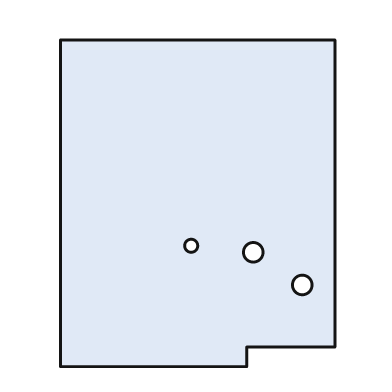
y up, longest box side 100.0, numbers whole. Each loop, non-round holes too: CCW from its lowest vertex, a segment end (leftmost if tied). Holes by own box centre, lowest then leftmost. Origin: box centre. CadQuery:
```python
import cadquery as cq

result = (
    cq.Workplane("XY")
    .moveTo(-42.0, -50.0)
    .lineTo(15.0, -50.0)
    .lineTo(15.0, -44.0)
    .lineTo(42.0, -44.0)
    .lineTo(42.0, 50.0)
    .lineTo(-42.0, 50.0)
    .close()
    .moveTo(32.0, -25.0)
    .circle(3.0)
    .moveTo(17.0, -15.0)
    .circle(3.0)
    .moveTo(-2.0, -13.0)
    .circle(2.0)
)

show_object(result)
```